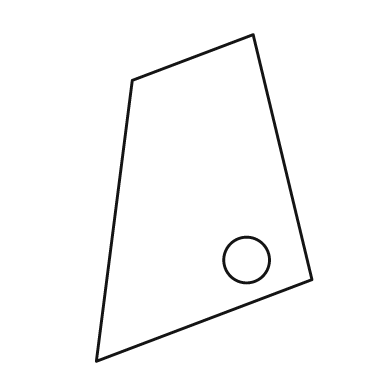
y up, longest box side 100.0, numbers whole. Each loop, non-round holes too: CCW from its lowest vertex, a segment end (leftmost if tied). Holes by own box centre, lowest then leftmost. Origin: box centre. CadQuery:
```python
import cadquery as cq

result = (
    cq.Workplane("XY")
    .moveTo(-33.0, -50.0)
    .lineTo(33.0, -25.0)
    .lineTo(15.0, 50.0)
    .lineTo(-22.0, 36.0)
    .close()
    .moveTo(13.0, -19.0)
    .circle(7.0)
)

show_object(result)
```